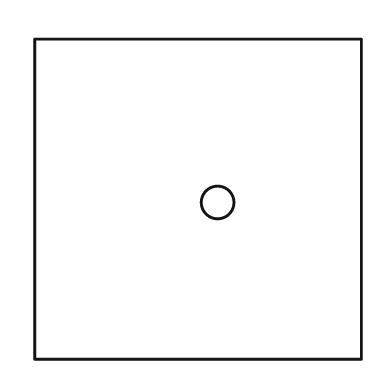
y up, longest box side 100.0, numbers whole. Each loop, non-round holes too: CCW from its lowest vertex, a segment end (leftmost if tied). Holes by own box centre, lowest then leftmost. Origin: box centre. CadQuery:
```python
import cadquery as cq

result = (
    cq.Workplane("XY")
    .moveTo(-50.0, -49.0)
    .lineTo(50.0, -49.0)
    .lineTo(50.0, 49.0)
    .lineTo(-50.0, 49.0)
    .close()
    .moveTo(6.0, -1.0)
    .circle(5.0)
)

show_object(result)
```